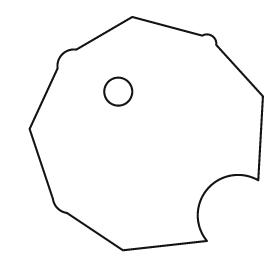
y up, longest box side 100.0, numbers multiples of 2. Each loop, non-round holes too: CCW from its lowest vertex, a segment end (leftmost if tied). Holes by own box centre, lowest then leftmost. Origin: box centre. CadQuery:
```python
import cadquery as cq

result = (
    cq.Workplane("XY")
    .moveTo(-10.0, -50.0)
    .lineTo(26.0, -46.0)
    .threePointArc((26.0, -24.0), (48.0, -20.0))
    .lineTo(50.0, 16.0)
    .lineTo(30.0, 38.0)
    .threePointArc((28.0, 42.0), (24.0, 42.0))
    .lineTo(-6.0, 50.0)
    .lineTo(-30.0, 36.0)
    .threePointArc((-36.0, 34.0), (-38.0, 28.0))
    .lineTo(-50.0, 2.0)
    .lineTo(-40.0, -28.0)
    .threePointArc((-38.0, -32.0), (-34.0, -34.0))
    .close()
    .moveTo(-12.0, 18.0)
    .circle(6.0)
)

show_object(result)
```